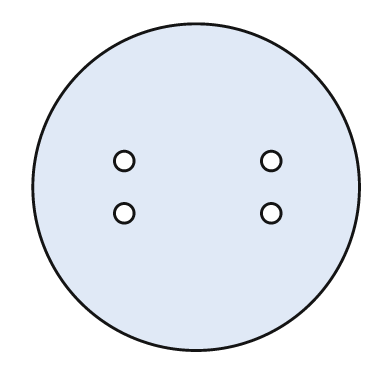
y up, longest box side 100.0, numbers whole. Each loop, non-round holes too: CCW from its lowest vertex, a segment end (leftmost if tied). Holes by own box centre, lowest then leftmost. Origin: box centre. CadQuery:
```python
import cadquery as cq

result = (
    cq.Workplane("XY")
    .moveTo(0.0, 0.0)
    .circle(50.0)
    .moveTo(-22.0, -8.0)
    .circle(3.0)
    .moveTo(23.0, -8.0)
    .circle(3.0)
    .moveTo(-22.0, 8.0)
    .circle(3.0)
    .moveTo(23.0, 8.0)
    .circle(3.0)
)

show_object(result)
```